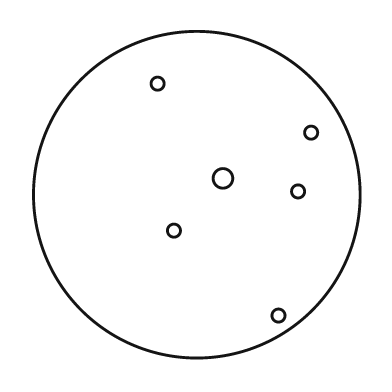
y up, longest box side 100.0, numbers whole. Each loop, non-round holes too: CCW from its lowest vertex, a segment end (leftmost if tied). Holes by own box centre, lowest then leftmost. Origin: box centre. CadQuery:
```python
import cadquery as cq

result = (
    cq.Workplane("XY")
    .moveTo(0.0, 0.0)
    .circle(50.0)
    .moveTo(25.0, -37.0)
    .circle(2.0)
    .moveTo(-7.0, -11.0)
    .circle(2.0)
    .moveTo(31.0, 1.0)
    .circle(2.0)
    .moveTo(8.0, 5.0)
    .circle(3.0)
    .moveTo(35.0, 19.0)
    .circle(2.0)
    .moveTo(-12.0, 34.0)
    .circle(2.0)
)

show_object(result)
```